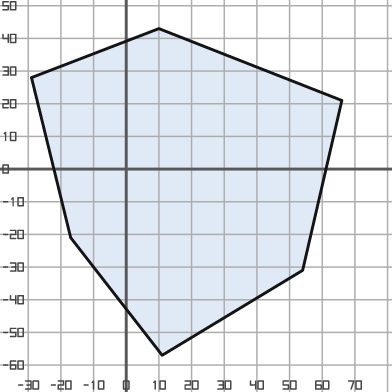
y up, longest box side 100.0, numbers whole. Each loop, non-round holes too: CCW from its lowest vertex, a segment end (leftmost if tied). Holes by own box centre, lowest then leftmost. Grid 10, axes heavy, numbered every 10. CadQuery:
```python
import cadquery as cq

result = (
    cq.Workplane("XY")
    .moveTo(11.0, -57.0)
    .lineTo(54.0, -31.0)
    .lineTo(66.0, 21.0)
    .lineTo(10.0, 43.0)
    .lineTo(-29.0, 28.0)
    .lineTo(-17.0, -21.0)
    .close()
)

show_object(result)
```